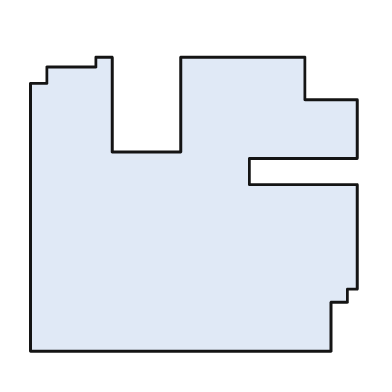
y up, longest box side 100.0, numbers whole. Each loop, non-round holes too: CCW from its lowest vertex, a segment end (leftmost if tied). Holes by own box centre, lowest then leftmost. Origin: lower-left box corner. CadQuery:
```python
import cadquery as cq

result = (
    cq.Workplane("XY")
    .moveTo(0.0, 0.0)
    .lineTo(92.0, 0.0)
    .lineTo(92.0, 15.0)
    .lineTo(97.0, 15.0)
    .lineTo(97.0, 19.0)
    .lineTo(100.0, 19.0)
    .lineTo(100.0, 51.0)
    .lineTo(67.0, 51.0)
    .lineTo(67.0, 59.0)
    .lineTo(100.0, 59.0)
    .lineTo(100.0, 77.0)
    .lineTo(84.0, 77.0)
    .lineTo(84.0, 90.0)
    .lineTo(46.0, 90.0)
    .lineTo(46.0, 61.0)
    .lineTo(25.0, 61.0)
    .lineTo(25.0, 90.0)
    .lineTo(20.0, 90.0)
    .lineTo(20.0, 87.0)
    .lineTo(5.0, 87.0)
    .lineTo(5.0, 82.0)
    .lineTo(0.0, 82.0)
    .close()
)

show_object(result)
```